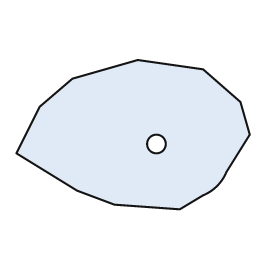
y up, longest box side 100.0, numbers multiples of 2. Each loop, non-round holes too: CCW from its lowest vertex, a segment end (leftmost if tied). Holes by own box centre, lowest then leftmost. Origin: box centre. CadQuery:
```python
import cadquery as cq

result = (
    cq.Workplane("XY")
    .moveTo(20.0, -32.0)
    .lineTo(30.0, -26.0)
    .threePointArc((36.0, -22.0), (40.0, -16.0))
    .lineTo(50.0, 0.0)
    .lineTo(46.0, 14.0)
    .lineTo(30.0, 28.0)
    .lineTo(2.0, 32.0)
    .lineTo(-26.0, 24.0)
    .lineTo(-40.0, 12.0)
    .lineTo(-50.0, -8.0)
    .lineTo(-24.0, -24.0)
    .lineTo(-8.0, -30.0)
    .close()
    .moveTo(10.0, -4.0)
    .circle(4.0)
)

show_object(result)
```